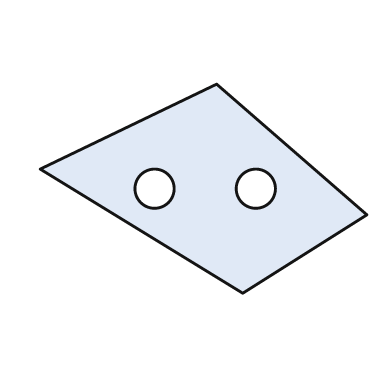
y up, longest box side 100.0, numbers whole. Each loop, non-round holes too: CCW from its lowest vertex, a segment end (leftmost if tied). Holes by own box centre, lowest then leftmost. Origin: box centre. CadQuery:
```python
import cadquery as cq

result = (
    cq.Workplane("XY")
    .moveTo(12.0, -32.0)
    .lineTo(50.0, -8.0)
    .lineTo(4.0, 32.0)
    .lineTo(-50.0, 6.0)
    .close()
    .moveTo(-15.0, 0.0)
    .circle(6.0)
    .moveTo(16.0, 0.0)
    .circle(6.0)
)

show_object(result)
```